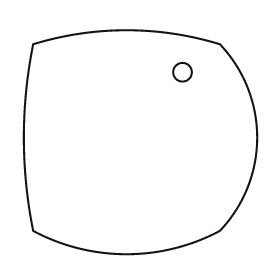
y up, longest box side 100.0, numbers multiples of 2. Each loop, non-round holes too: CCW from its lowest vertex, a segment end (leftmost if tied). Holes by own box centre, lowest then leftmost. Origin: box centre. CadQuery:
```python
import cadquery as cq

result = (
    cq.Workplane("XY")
    .moveTo(-46.0, -38.0)
    .threePointArc((-6.0, -48.0), (34.0, -38.0))
    .threePointArc((50.0, 2.0), (34.0, 42.0))
    .threePointArc((-6.0, 48.0), (-46.0, 42.0))
    .threePointArc((-50.0, 2.0), (-46.0, -38.0))
    .close()
    .moveTo(18.0, 30.0)
    .circle(4.0)
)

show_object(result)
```